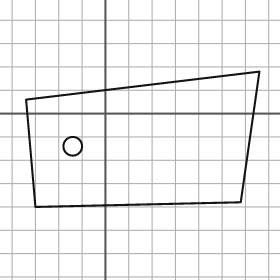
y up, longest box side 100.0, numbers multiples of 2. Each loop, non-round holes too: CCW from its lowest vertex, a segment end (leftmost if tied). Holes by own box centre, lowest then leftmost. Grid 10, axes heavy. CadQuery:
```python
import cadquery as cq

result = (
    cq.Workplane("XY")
    .moveTo(-30.0, -40.0)
    .lineTo(58.0, -38.0)
    .lineTo(66.0, 18.0)
    .lineTo(-34.0, 6.0)
    .close()
    .moveTo(-14.0, -14.0)
    .circle(4.0)
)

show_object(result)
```